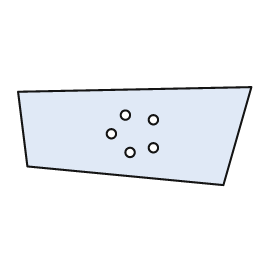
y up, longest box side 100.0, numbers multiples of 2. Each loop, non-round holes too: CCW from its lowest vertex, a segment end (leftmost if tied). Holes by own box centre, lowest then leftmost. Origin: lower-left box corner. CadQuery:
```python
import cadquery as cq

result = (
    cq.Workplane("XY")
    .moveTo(88.0, 0.0)
    .lineTo(100.0, 42.0)
    .lineTo(0.0, 40.0)
    .lineTo(4.0, 8.0)
    .close()
    .moveTo(48.0, 14.0)
    .circle(2.0)
    .moveTo(58.0, 16.0)
    .circle(2.0)
    .moveTo(40.0, 22.0)
    .circle(2.0)
    .moveTo(58.0, 28.0)
    .circle(2.0)
    .moveTo(46.0, 30.0)
    .circle(2.0)
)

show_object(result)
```